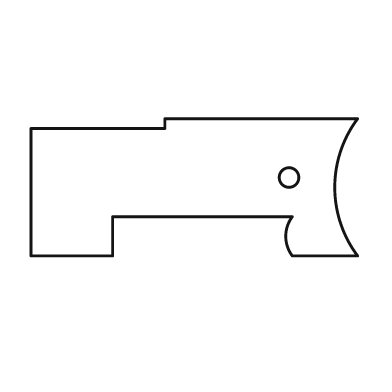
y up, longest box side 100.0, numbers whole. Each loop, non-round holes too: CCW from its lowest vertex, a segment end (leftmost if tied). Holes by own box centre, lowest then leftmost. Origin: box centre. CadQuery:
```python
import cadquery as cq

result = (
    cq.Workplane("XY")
    .moveTo(-50.0, -21.0)
    .lineTo(-25.0, -21.0)
    .lineTo(-25.0, -9.0)
    .lineTo(30.0, -9.0)
    .threePointArc((28.0, -15.0), (30.0, -21.0))
    .lineTo(50.0, -21.0)
    .threePointArc((43.0, 0.0), (50.0, 21.0))
    .lineTo(-9.0, 21.0)
    .lineTo(-9.0, 18.0)
    .lineTo(-50.0, 18.0)
    .close()
    .moveTo(29.0, 3.0)
    .circle(3.0)
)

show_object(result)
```